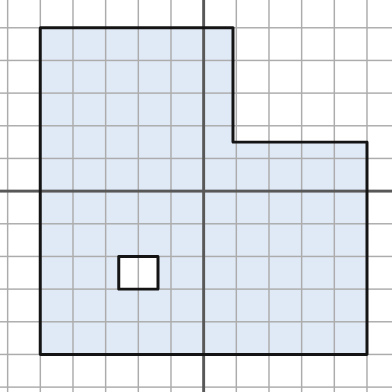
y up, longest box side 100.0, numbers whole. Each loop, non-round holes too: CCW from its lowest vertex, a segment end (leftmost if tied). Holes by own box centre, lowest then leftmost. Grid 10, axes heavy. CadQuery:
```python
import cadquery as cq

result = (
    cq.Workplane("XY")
    .moveTo(-50.0, -50.0)
    .lineTo(50.0, -50.0)
    .lineTo(50.0, 15.0)
    .lineTo(9.0, 15.0)
    .lineTo(9.0, 50.0)
    .lineTo(-50.0, 50.0)
    .close()
    .moveTo(-26.0, -30.0)
    .lineTo(-14.0, -30.0)
    .lineTo(-14.0, -20.0)
    .lineTo(-26.0, -20.0)
    .close()
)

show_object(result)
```